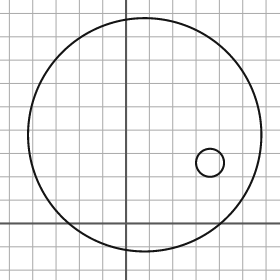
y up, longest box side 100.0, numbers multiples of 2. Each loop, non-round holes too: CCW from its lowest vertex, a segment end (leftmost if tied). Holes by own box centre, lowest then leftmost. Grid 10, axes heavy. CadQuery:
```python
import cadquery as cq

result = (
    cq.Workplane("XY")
    .moveTo(8.0, 38.0)
    .circle(50.0)
    .moveTo(36.0, 26.0)
    .circle(6.0)
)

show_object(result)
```